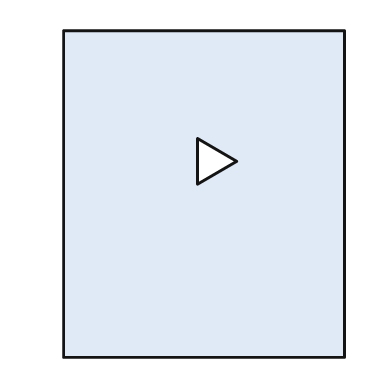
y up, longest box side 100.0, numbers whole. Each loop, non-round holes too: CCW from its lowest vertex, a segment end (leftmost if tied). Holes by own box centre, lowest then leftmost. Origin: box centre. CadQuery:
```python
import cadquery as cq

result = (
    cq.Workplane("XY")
    .moveTo(-43.0, -50.0)
    .lineTo(43.0, -50.0)
    .lineTo(43.0, 50.0)
    .lineTo(-43.0, 50.0)
    .close()
    .moveTo(-2.0, 3.0)
    .lineTo(10.0, 10.0)
    .lineTo(-2.0, 17.0)
    .close()
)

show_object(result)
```